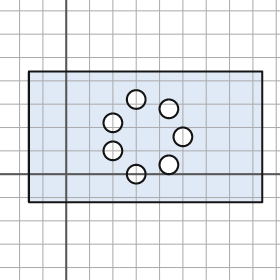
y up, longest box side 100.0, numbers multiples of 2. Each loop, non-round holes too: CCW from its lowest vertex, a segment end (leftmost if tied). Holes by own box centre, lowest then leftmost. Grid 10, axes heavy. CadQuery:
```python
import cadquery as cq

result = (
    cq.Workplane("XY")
    .moveTo(-16.0, -12.0)
    .lineTo(84.0, -12.0)
    .lineTo(84.0, 44.0)
    .lineTo(-16.0, 44.0)
    .close()
    .moveTo(30.0, 0.0)
    .circle(4.0)
    .moveTo(44.0, 4.0)
    .circle(4.0)
    .moveTo(20.0, 10.0)
    .circle(4.0)
    .moveTo(50.0, 16.0)
    .circle(4.0)
    .moveTo(20.0, 22.0)
    .circle(4.0)
    .moveTo(44.0, 28.0)
    .circle(4.0)
    .moveTo(30.0, 32.0)
    .circle(4.0)
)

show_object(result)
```